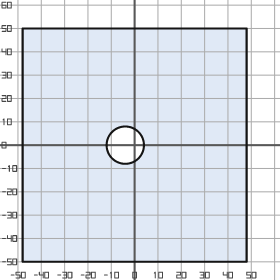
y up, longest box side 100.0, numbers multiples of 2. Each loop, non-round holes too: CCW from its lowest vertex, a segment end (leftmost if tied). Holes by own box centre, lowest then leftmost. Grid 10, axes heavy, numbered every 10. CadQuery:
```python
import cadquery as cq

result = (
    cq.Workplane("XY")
    .moveTo(-48.0, -50.0)
    .lineTo(48.0, -50.0)
    .lineTo(48.0, 50.0)
    .lineTo(-48.0, 50.0)
    .close()
    .moveTo(-4.0, 0.0)
    .circle(8.0)
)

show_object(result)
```